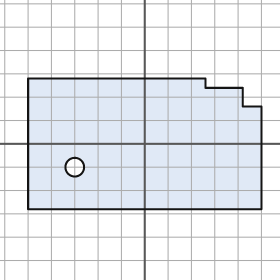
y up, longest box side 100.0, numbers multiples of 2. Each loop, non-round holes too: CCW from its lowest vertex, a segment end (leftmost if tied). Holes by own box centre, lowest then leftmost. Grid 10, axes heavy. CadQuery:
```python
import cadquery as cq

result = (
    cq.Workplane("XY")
    .moveTo(-50.0, -28.0)
    .lineTo(50.0, -28.0)
    .lineTo(50.0, 16.0)
    .lineTo(42.0, 16.0)
    .lineTo(42.0, 24.0)
    .lineTo(26.0, 24.0)
    .lineTo(26.0, 28.0)
    .lineTo(-50.0, 28.0)
    .close()
    .moveTo(-30.0, -10.0)
    .circle(4.0)
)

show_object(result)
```